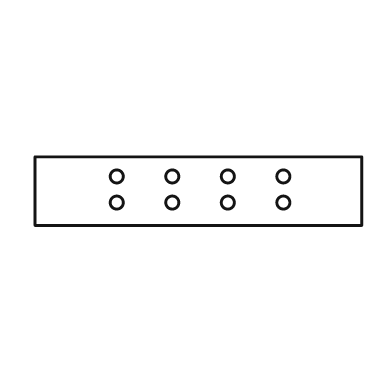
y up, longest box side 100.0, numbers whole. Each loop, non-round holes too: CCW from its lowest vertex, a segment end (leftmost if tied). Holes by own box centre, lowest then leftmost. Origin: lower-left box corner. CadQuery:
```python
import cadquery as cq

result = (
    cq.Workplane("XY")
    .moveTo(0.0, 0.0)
    .lineTo(100.0, 0.0)
    .lineTo(100.0, 21.0)
    .lineTo(0.0, 21.0)
    .close()
    .moveTo(25.0, 7.0)
    .circle(2.0)
    .moveTo(42.0, 7.0)
    .circle(2.0)
    .moveTo(59.0, 7.0)
    .circle(2.0)
    .moveTo(76.0, 7.0)
    .circle(2.0)
    .moveTo(25.0, 15.0)
    .circle(2.0)
    .moveTo(42.0, 15.0)
    .circle(2.0)
    .moveTo(59.0, 15.0)
    .circle(2.0)
    .moveTo(76.0, 15.0)
    .circle(2.0)
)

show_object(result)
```